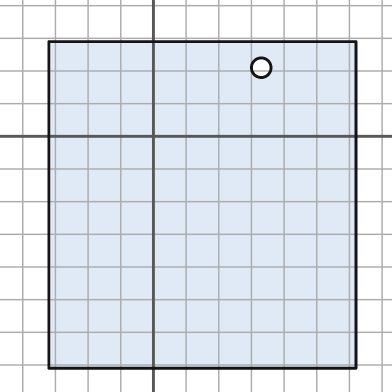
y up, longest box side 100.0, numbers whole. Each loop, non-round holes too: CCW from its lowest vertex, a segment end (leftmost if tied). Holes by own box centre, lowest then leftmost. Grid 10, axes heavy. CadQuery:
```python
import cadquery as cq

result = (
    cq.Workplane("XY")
    .moveTo(-32.0, -71.0)
    .lineTo(62.0, -71.0)
    .lineTo(62.0, 29.0)
    .lineTo(-32.0, 29.0)
    .close()
    .moveTo(33.0, 21.0)
    .circle(3.0)
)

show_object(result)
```